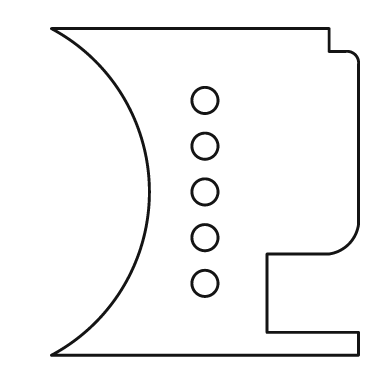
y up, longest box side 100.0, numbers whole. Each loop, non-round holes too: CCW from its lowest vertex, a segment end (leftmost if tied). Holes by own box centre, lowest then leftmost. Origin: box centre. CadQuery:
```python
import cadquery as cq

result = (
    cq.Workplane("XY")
    .moveTo(-47.0, -50.0)
    .lineTo(47.0, -50.0)
    .lineTo(47.0, -43.0)
    .lineTo(19.0, -43.0)
    .lineTo(19.0, -19.0)
    .lineTo(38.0, -19.0)
    .threePointArc((44.0, -16.0), (47.0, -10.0))
    .lineTo(47.0, 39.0)
    .threePointArc((46.0, 42.0), (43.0, 43.0))
    .lineTo(38.0, 43.0)
    .lineTo(38.0, 50.0)
    .lineTo(-47.0, 50.0)
    .threePointArc((-17.0, 0.0), (-47.0, -50.0))
    .close()
    .moveTo(0.0, -28.0)
    .circle(4.0)
    .moveTo(0.0, -14.0)
    .circle(4.0)
    .moveTo(0.0, 0.0)
    .circle(4.0)
    .moveTo(0.0, 14.0)
    .circle(4.0)
    .moveTo(0.0, 28.0)
    .circle(4.0)
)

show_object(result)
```